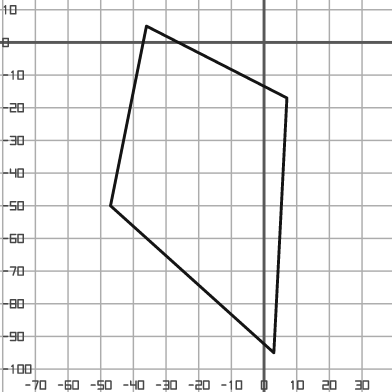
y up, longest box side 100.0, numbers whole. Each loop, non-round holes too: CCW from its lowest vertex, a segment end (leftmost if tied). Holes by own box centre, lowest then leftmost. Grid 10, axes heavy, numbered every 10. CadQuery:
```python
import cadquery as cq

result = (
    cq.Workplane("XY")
    .moveTo(3.0, -95.0)
    .lineTo(7.0, -17.0)
    .lineTo(-36.0, 5.0)
    .lineTo(-47.0, -50.0)
    .close()
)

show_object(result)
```